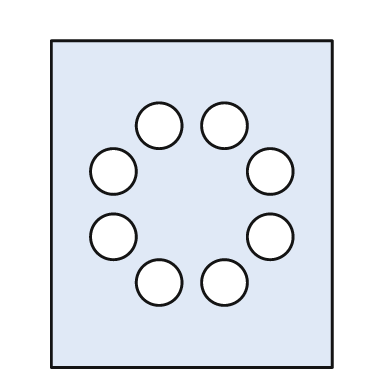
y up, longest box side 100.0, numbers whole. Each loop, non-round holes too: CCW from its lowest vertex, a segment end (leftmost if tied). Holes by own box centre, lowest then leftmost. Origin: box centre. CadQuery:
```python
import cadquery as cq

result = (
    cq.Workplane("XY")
    .moveTo(-43.0, -50.0)
    .lineTo(43.0, -50.0)
    .lineTo(43.0, 50.0)
    .lineTo(-43.0, 50.0)
    .close()
    .moveTo(-10.0, -24.0)
    .circle(7.0)
    .moveTo(10.0, -24.0)
    .circle(7.0)
    .moveTo(-24.0, -10.0)
    .circle(7.0)
    .moveTo(24.0, -10.0)
    .circle(7.0)
    .moveTo(-24.0, 10.0)
    .circle(7.0)
    .moveTo(24.0, 10.0)
    .circle(7.0)
    .moveTo(-10.0, 24.0)
    .circle(7.0)
    .moveTo(10.0, 24.0)
    .circle(7.0)
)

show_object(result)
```